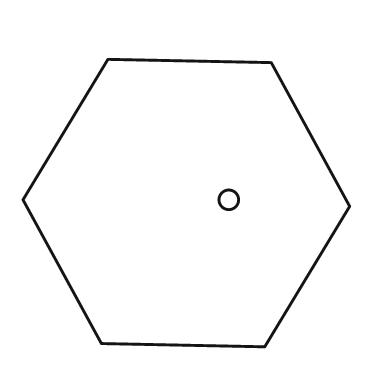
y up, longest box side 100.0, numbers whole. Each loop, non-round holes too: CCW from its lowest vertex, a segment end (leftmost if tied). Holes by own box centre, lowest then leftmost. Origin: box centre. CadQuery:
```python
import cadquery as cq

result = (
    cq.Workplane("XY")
    .moveTo(24.0, -44.0)
    .lineTo(50.0, -1.0)
    .lineTo(26.0, 43.0)
    .lineTo(-24.0, 44.0)
    .lineTo(-50.0, 1.0)
    .lineTo(-26.0, -43.0)
    .close()
    .moveTo(13.0, 1.0)
    .circle(3.0)
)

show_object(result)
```